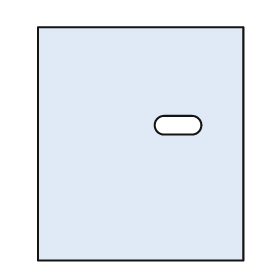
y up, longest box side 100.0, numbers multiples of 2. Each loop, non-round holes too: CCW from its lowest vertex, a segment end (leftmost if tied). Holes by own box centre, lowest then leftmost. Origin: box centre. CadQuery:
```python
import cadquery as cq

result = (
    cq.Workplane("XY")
    .moveTo(-44.0, -50.0)
    .lineTo(44.0, -50.0)
    .lineTo(44.0, 50.0)
    .lineTo(-44.0, 50.0)
    .close()
    .moveTo(10.0, 4.0)
    .lineTo(22.0, 4.0)
    .threePointArc((26.0, 8.0), (22.0, 12.0))
    .lineTo(10.0, 12.0)
    .threePointArc((6.0, 8.0), (10.0, 4.0))
    .close()
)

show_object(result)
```